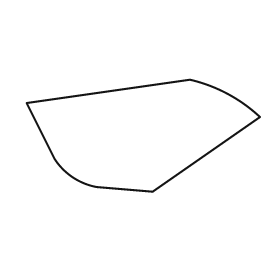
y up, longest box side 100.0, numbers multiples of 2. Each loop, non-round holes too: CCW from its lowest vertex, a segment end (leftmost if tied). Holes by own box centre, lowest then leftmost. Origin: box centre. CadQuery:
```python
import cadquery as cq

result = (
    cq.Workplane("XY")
    .moveTo(4.0, -24.0)
    .lineTo(50.0, 8.0)
    .threePointArc((36.0, 18.0), (20.0, 24.0))
    .lineTo(-50.0, 14.0)
    .lineTo(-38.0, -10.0)
    .threePointArc((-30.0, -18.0), (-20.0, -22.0))
    .close()
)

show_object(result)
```